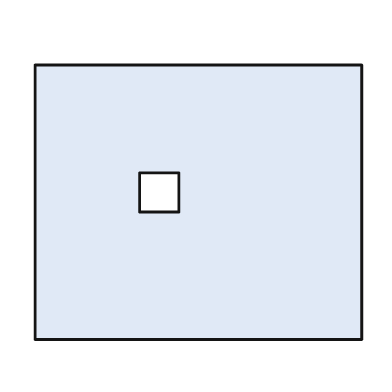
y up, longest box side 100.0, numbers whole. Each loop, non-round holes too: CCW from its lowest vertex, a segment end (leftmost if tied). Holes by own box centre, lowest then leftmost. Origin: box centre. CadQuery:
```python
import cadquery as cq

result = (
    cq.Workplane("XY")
    .moveTo(-50.0, -42.0)
    .lineTo(50.0, -42.0)
    .lineTo(50.0, 42.0)
    .lineTo(-50.0, 42.0)
    .close()
    .moveTo(-18.0, -3.0)
    .lineTo(-6.0, -3.0)
    .lineTo(-6.0, 9.0)
    .lineTo(-18.0, 9.0)
    .close()
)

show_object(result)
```